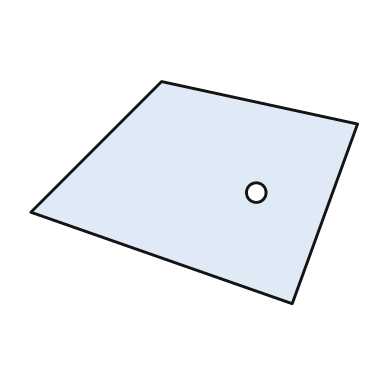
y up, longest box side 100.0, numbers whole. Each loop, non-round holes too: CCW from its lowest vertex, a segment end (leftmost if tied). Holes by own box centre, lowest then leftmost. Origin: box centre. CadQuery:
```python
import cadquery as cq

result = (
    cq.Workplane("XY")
    .moveTo(30.0, -34.0)
    .lineTo(50.0, 21.0)
    .lineTo(-10.0, 34.0)
    .lineTo(-50.0, -6.0)
    .close()
    .moveTo(19.0, 0.0)
    .circle(3.0)
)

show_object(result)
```